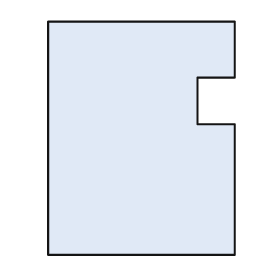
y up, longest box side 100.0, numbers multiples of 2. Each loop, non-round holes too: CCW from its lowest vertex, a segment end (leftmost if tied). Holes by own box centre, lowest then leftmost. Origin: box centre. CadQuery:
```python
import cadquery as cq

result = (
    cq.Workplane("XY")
    .moveTo(-40.0, -50.0)
    .lineTo(40.0, -50.0)
    .lineTo(40.0, 6.0)
    .lineTo(24.0, 6.0)
    .lineTo(24.0, 26.0)
    .lineTo(40.0, 26.0)
    .lineTo(40.0, 50.0)
    .lineTo(-40.0, 50.0)
    .close()
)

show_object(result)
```